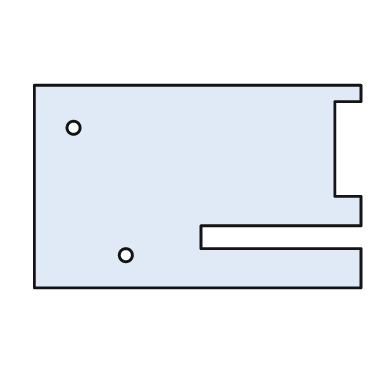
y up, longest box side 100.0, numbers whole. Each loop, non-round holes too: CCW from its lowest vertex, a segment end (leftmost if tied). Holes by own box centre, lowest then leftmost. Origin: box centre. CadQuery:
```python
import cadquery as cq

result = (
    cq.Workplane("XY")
    .moveTo(-50.0, -31.0)
    .lineTo(50.0, -31.0)
    .lineTo(50.0, -19.0)
    .lineTo(1.0, -19.0)
    .lineTo(1.0, -12.0)
    .lineTo(50.0, -12.0)
    .lineTo(50.0, -3.0)
    .lineTo(42.0, -3.0)
    .lineTo(42.0, 26.0)
    .lineTo(50.0, 26.0)
    .lineTo(50.0, 31.0)
    .lineTo(-50.0, 31.0)
    .close()
    .moveTo(-22.0, -21.0)
    .circle(2.0)
    .moveTo(-38.0, 18.0)
    .circle(2.0)
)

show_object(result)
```